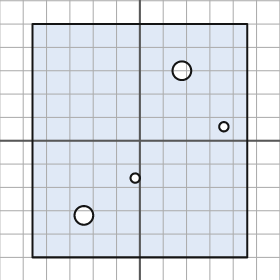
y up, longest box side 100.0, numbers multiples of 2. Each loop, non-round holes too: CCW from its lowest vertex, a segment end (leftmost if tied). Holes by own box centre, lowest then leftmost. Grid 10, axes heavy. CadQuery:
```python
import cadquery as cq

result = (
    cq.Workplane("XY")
    .moveTo(-46.0, -50.0)
    .lineTo(46.0, -50.0)
    .lineTo(46.0, 50.0)
    .lineTo(-46.0, 50.0)
    .close()
    .moveTo(-24.0, -32.0)
    .circle(4.0)
    .moveTo(-2.0, -16.0)
    .circle(2.0)
    .moveTo(36.0, 6.0)
    .circle(2.0)
    .moveTo(18.0, 30.0)
    .circle(4.0)
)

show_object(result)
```